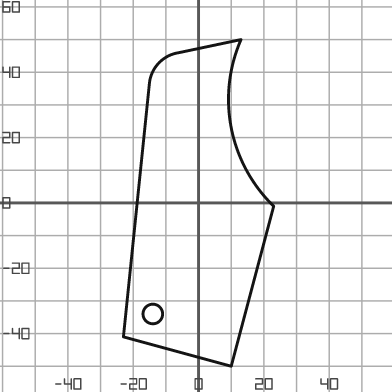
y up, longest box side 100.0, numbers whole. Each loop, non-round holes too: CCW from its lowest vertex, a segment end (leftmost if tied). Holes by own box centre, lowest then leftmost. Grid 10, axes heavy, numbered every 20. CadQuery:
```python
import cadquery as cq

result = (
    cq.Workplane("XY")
    .moveTo(10.0, -50.0)
    .lineTo(23.0, -1.0)
    .threePointArc((10.0, 23.0), (13.0, 50.0))
    .lineTo(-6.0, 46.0)
    .threePointArc((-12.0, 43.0), (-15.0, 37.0))
    .lineTo(-23.0, -41.0)
    .close()
    .moveTo(-14.0, -34.0)
    .circle(3.0)
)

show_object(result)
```